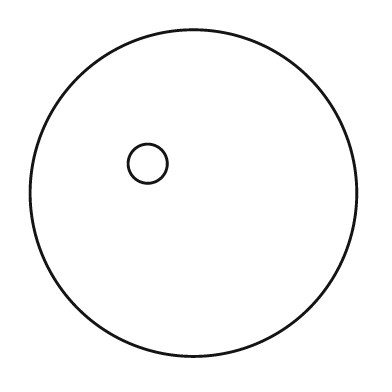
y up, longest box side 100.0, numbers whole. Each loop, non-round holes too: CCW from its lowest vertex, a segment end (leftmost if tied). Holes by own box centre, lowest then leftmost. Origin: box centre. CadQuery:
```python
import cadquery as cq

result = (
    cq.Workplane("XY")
    .moveTo(0.0, 0.0)
    .circle(50.0)
    .moveTo(-14.0, 9.0)
    .circle(6.0)
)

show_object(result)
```